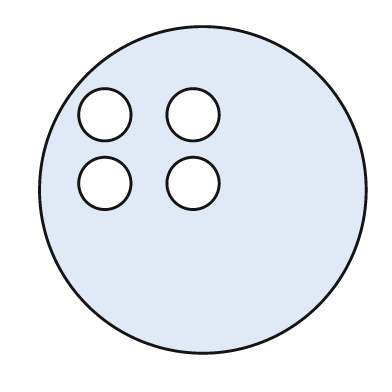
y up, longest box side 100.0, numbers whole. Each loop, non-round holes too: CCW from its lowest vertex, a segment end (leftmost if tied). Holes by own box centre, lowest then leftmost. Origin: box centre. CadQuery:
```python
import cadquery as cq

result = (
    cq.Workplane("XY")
    .moveTo(0.0, 0.0)
    .circle(50.0)
    .moveTo(-30.0, 2.0)
    .circle(8.0)
    .moveTo(-3.0, 2.0)
    .circle(8.0)
    .moveTo(-30.0, 23.0)
    .circle(8.0)
    .moveTo(-3.0, 23.0)
    .circle(8.0)
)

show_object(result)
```